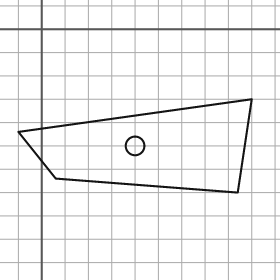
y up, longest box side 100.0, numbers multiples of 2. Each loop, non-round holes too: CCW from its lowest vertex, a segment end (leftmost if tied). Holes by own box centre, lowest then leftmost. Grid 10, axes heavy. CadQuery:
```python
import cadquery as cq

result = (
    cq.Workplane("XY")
    .moveTo(84.0, -70.0)
    .lineTo(90.0, -30.0)
    .lineTo(-10.0, -44.0)
    .lineTo(6.0, -64.0)
    .close()
    .moveTo(40.0, -50.0)
    .circle(4.0)
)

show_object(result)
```